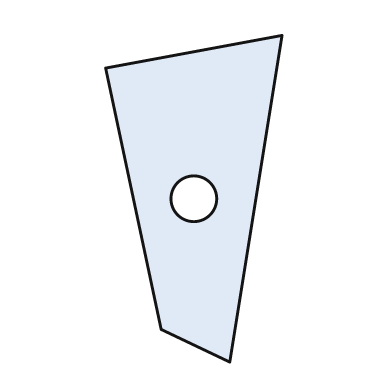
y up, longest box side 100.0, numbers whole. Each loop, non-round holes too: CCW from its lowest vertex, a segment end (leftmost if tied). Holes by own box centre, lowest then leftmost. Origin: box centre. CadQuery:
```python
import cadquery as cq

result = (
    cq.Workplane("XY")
    .moveTo(11.0, -50.0)
    .lineTo(27.0, 50.0)
    .lineTo(-27.0, 40.0)
    .lineTo(-10.0, -40.0)
    .close()
    .moveTo(0.0, 0.0)
    .circle(7.0)
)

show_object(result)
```